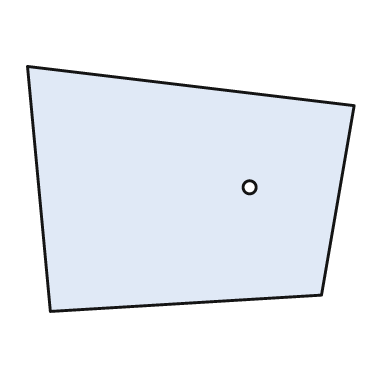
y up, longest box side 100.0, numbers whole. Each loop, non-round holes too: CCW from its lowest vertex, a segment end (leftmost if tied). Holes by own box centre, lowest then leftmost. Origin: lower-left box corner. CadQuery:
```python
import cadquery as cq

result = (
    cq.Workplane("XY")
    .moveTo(7.0, 0.0)
    .lineTo(90.0, 5.0)
    .lineTo(100.0, 63.0)
    .lineTo(0.0, 75.0)
    .close()
    .moveTo(68.0, 38.0)
    .circle(2.0)
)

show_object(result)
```